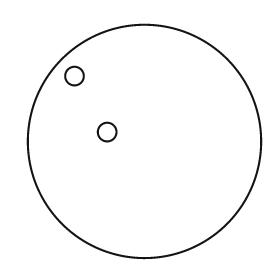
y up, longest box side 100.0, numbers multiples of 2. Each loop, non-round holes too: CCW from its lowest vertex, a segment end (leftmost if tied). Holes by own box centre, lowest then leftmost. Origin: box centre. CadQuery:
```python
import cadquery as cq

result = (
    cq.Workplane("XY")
    .moveTo(0.0, 0.0)
    .circle(50.0)
    .moveTo(-16.0, 4.0)
    .circle(4.0)
    .moveTo(-30.0, 28.0)
    .circle(4.0)
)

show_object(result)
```